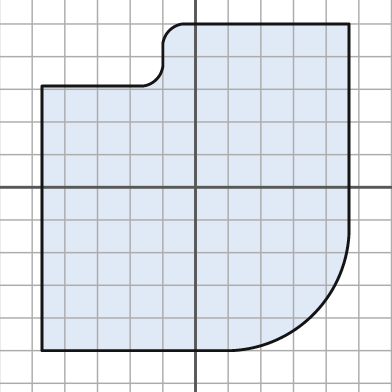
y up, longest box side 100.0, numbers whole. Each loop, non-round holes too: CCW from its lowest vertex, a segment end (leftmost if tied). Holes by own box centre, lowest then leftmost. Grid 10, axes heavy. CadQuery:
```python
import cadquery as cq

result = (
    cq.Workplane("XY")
    .moveTo(-47.0, -50.0)
    .lineTo(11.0, -50.0)
    .threePointArc((36.0, -39.0), (47.0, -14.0))
    .lineTo(47.0, 50.0)
    .lineTo(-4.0, 50.0)
    .threePointArc((-8.0, 48.0), (-10.0, 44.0))
    .lineTo(-10.0, 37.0)
    .threePointArc((-12.0, 33.0), (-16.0, 31.0))
    .lineTo(-47.0, 31.0)
    .close()
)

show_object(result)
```